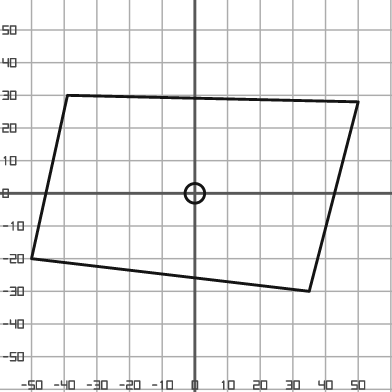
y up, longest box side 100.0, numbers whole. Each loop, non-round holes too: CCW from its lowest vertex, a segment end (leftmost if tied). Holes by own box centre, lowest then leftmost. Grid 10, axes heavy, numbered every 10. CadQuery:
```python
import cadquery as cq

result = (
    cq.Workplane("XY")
    .moveTo(35.0, -30.0)
    .lineTo(50.0, 28.0)
    .lineTo(-39.0, 30.0)
    .lineTo(-50.0, -20.0)
    .close()
    .moveTo(0.0, 0.0)
    .circle(3.0)
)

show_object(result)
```